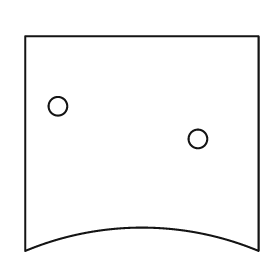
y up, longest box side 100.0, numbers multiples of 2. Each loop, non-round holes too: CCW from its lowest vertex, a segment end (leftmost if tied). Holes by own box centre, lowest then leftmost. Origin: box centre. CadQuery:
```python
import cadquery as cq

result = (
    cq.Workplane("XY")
    .moveTo(-50.0, -46.0)
    .threePointArc((0.0, -36.0), (50.0, -46.0))
    .lineTo(50.0, 46.0)
    .lineTo(-50.0, 46.0)
    .close()
    .moveTo(24.0, 2.0)
    .circle(4.0)
    .moveTo(-36.0, 16.0)
    .circle(4.0)
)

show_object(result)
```